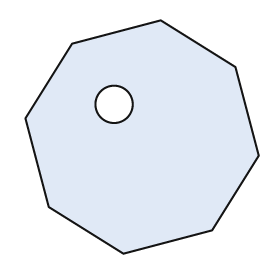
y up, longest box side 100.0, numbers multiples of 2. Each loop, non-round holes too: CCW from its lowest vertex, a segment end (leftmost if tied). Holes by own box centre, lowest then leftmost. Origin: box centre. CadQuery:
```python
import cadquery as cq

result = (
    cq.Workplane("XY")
    .moveTo(-8.0, -50.0)
    .lineTo(30.0, -40.0)
    .lineTo(50.0, -8.0)
    .lineTo(40.0, 30.0)
    .lineTo(8.0, 50.0)
    .lineTo(-30.0, 40.0)
    .lineTo(-50.0, 8.0)
    .lineTo(-40.0, -30.0)
    .close()
    .moveTo(-12.0, 14.0)
    .circle(8.0)
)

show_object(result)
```